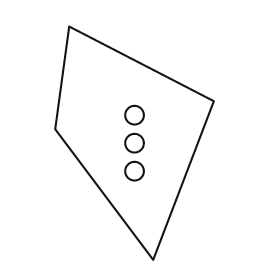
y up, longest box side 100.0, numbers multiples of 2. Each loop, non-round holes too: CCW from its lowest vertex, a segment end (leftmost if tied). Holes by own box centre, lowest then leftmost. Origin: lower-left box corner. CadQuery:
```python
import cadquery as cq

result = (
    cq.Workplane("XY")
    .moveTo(42.0, 0.0)
    .lineTo(68.0, 68.0)
    .lineTo(6.0, 100.0)
    .lineTo(0.0, 56.0)
    .close()
    .moveTo(34.0, 38.0)
    .circle(4.0)
    .moveTo(34.0, 50.0)
    .circle(4.0)
    .moveTo(34.0, 62.0)
    .circle(4.0)
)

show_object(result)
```